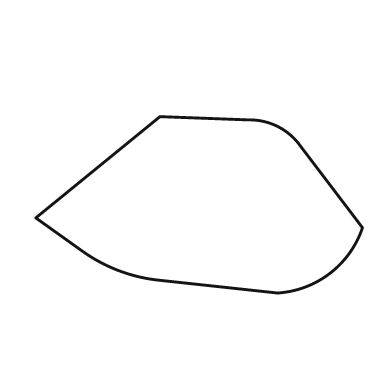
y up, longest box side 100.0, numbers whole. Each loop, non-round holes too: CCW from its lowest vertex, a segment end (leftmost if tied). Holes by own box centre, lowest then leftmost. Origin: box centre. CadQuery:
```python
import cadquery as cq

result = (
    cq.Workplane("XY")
    .moveTo(24.0, -27.0)
    .threePointArc((40.0, -21.0), (50.0, -7.0))
    .lineTo(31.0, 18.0)
    .threePointArc((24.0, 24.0), (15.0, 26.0))
    .lineTo(-12.0, 27.0)
    .lineTo(-50.0, -4.0)
    .lineTo(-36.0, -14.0)
    .threePointArc((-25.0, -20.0), (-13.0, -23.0))
    .close()
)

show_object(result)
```